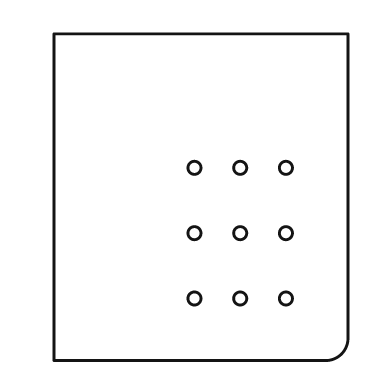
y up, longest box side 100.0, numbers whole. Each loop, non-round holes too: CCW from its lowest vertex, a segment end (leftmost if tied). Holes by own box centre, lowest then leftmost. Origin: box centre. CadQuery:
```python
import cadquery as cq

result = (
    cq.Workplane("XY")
    .moveTo(-45.0, -50.0)
    .lineTo(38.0, -50.0)
    .threePointArc((43.0, -48.0), (45.0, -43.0))
    .lineTo(45.0, 50.0)
    .lineTo(-45.0, 50.0)
    .close()
    .moveTo(-2.0, -31.0)
    .circle(2.0)
    .moveTo(12.0, -31.0)
    .circle(2.0)
    .moveTo(26.0, -31.0)
    .circle(2.0)
    .moveTo(-2.0, -11.0)
    .circle(2.0)
    .moveTo(12.0, -11.0)
    .circle(2.0)
    .moveTo(26.0, -11.0)
    .circle(2.0)
    .moveTo(-2.0, 9.0)
    .circle(2.0)
    .moveTo(12.0, 9.0)
    .circle(2.0)
    .moveTo(26.0, 9.0)
    .circle(2.0)
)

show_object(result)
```